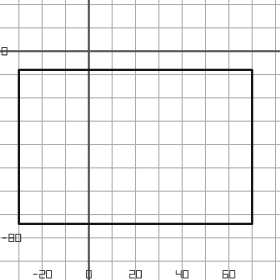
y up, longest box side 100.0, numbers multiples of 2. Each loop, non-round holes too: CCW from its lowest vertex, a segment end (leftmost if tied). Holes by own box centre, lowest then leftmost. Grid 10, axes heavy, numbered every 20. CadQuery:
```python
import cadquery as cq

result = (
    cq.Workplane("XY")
    .moveTo(-30.0, -74.0)
    .lineTo(70.0, -74.0)
    .lineTo(70.0, -8.0)
    .lineTo(-30.0, -8.0)
    .close()
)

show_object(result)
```